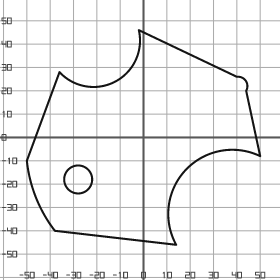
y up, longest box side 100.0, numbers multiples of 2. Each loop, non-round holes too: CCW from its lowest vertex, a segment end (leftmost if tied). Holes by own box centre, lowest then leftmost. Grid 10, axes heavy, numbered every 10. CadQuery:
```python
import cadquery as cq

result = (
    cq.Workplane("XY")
    .moveTo(14.0, -46.0)
    .threePointArc((18.0, -14.0), (50.0, -8.0))
    .lineTo(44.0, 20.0)
    .threePointArc((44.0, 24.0), (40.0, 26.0))
    .lineTo(-2.0, 46.0)
    .threePointArc((-12.0, 24.0), (-36.0, 28.0))
    .lineTo(-50.0, -10.0)
    .threePointArc((-46.0, -26.0), (-38.0, -40.0))
    .close()
    .moveTo(-28.0, -18.0)
    .circle(6.0)
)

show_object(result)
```